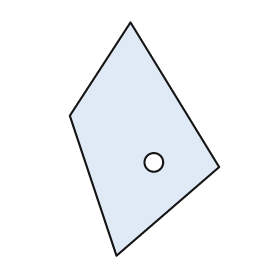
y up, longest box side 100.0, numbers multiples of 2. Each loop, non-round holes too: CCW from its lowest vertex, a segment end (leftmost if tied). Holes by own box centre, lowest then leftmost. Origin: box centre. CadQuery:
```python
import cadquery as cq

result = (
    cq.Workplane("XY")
    .moveTo(-12.0, -50.0)
    .lineTo(32.0, -12.0)
    .lineTo(-6.0, 50.0)
    .lineTo(-32.0, 10.0)
    .close()
    .moveTo(4.0, -10.0)
    .circle(4.0)
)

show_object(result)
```